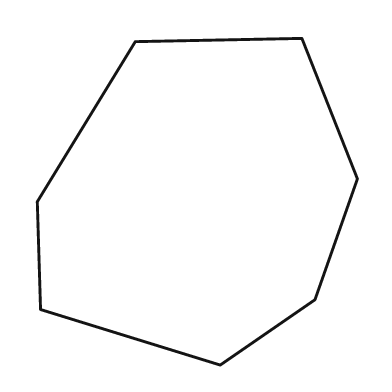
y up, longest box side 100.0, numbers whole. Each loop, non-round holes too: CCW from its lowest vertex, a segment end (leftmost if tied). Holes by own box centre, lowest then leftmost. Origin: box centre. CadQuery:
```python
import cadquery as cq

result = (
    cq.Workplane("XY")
    .moveTo(7.0, -50.0)
    .lineTo(36.0, -30.0)
    .lineTo(49.0, 7.0)
    .lineTo(32.0, 50.0)
    .lineTo(-19.0, 49.0)
    .lineTo(-49.0, 0.0)
    .lineTo(-48.0, -33.0)
    .close()
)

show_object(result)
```